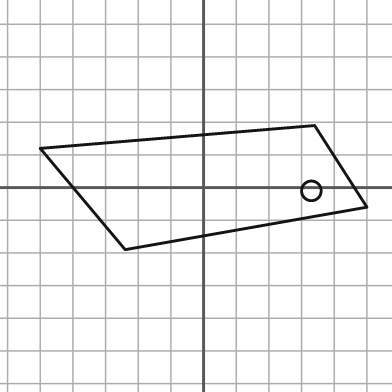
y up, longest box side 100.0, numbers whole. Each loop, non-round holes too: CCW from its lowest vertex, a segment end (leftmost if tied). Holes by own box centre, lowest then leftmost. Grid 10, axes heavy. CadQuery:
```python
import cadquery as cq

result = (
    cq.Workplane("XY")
    .moveTo(-24.0, -19.0)
    .lineTo(50.0, -6.0)
    .lineTo(34.0, 19.0)
    .lineTo(-50.0, 12.0)
    .close()
    .moveTo(33.0, -1.0)
    .circle(3.0)
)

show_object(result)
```